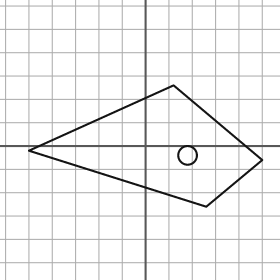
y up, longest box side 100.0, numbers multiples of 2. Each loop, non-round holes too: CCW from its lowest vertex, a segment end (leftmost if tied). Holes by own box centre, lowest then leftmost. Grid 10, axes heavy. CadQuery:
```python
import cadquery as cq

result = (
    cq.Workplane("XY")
    .moveTo(26.0, -26.0)
    .lineTo(50.0, -6.0)
    .lineTo(12.0, 26.0)
    .lineTo(-50.0, -2.0)
    .close()
    .moveTo(18.0, -4.0)
    .circle(4.0)
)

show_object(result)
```